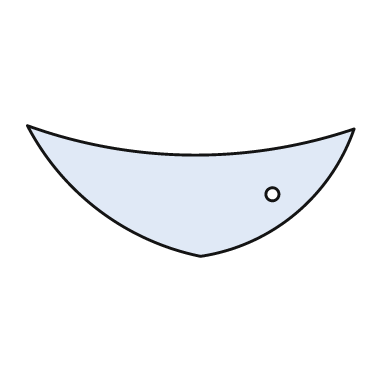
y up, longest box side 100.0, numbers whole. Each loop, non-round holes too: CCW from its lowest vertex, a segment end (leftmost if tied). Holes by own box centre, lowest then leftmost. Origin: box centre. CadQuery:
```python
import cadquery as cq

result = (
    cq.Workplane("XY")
    .moveTo(3.0, -20.0)
    .threePointArc((32.0, -7.0), (50.0, 19.0))
    .threePointArc((0.0, 11.0), (-50.0, 20.0))
    .threePointArc((-28.0, -6.0), (3.0, -20.0))
    .close()
    .moveTo(25.0, -1.0)
    .circle(2.0)
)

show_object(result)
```